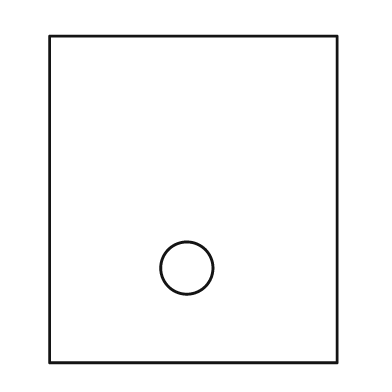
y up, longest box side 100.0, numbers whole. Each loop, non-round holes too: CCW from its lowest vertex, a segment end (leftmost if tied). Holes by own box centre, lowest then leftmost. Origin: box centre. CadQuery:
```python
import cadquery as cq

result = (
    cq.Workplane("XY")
    .moveTo(-44.0, -50.0)
    .lineTo(44.0, -50.0)
    .lineTo(44.0, 50.0)
    .lineTo(-44.0, 50.0)
    .close()
    .moveTo(-2.0, -21.0)
    .circle(8.0)
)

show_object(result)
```